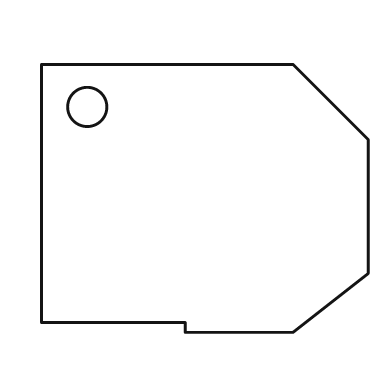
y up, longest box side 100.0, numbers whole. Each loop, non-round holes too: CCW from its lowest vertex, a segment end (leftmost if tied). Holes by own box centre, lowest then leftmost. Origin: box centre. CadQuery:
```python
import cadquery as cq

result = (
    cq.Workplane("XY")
    .moveTo(-6.0, -41.0)
    .lineTo(27.0, -41.0)
    .lineTo(50.0, -23.0)
    .lineTo(50.0, 18.0)
    .lineTo(27.0, 41.0)
    .lineTo(-50.0, 41.0)
    .lineTo(-50.0, -38.0)
    .lineTo(-6.0, -38.0)
    .close()
    .moveTo(-36.0, 28.0)
    .circle(6.0)
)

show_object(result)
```